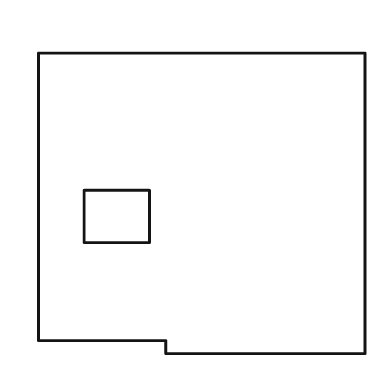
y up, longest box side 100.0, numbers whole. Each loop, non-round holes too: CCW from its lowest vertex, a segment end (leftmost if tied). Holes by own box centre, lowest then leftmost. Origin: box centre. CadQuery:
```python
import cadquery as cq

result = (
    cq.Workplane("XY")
    .moveTo(-11.0, -46.0)
    .lineTo(50.0, -46.0)
    .lineTo(50.0, 46.0)
    .lineTo(-50.0, 46.0)
    .lineTo(-50.0, -42.0)
    .lineTo(-11.0, -42.0)
    .close()
    .moveTo(-36.0, -12.0)
    .lineTo(-16.0, -12.0)
    .lineTo(-16.0, 4.0)
    .lineTo(-36.0, 4.0)
    .close()
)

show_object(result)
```